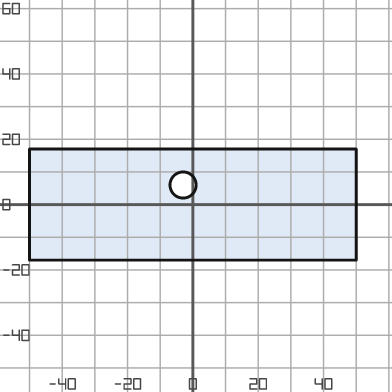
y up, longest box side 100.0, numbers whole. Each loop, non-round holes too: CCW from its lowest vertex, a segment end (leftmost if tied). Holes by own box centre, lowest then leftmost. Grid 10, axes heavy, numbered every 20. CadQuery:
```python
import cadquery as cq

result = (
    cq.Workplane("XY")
    .moveTo(-50.0, -17.0)
    .lineTo(50.0, -17.0)
    .lineTo(50.0, 17.0)
    .lineTo(-50.0, 17.0)
    .close()
    .moveTo(-3.0, 6.0)
    .circle(4.0)
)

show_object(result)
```